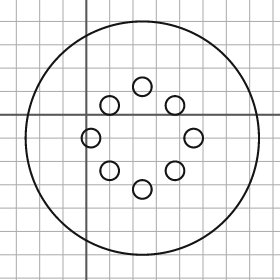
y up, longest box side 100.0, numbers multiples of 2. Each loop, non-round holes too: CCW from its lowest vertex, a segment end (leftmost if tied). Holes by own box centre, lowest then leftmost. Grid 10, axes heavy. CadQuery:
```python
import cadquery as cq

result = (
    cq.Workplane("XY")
    .moveTo(24.0, -10.0)
    .circle(50.0)
    .moveTo(24.0, -32.0)
    .circle(4.0)
    .moveTo(10.0, -24.0)
    .circle(4.0)
    .moveTo(38.0, -24.0)
    .circle(4.0)
    .moveTo(2.0, -10.0)
    .circle(4.0)
    .moveTo(46.0, -10.0)
    .circle(4.0)
    .moveTo(10.0, 4.0)
    .circle(4.0)
    .moveTo(38.0, 4.0)
    .circle(4.0)
    .moveTo(24.0, 12.0)
    .circle(4.0)
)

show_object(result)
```